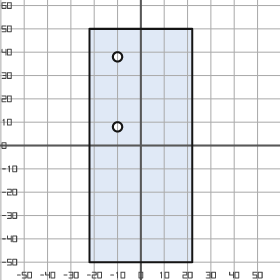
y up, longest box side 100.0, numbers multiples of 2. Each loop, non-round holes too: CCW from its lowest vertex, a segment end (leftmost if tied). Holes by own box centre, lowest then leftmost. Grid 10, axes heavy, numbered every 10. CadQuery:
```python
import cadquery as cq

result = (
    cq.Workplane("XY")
    .moveTo(-22.0, -50.0)
    .lineTo(22.0, -50.0)
    .lineTo(22.0, 50.0)
    .lineTo(-22.0, 50.0)
    .close()
    .moveTo(-10.0, 8.0)
    .circle(2.0)
    .moveTo(-10.0, 38.0)
    .circle(2.0)
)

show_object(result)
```